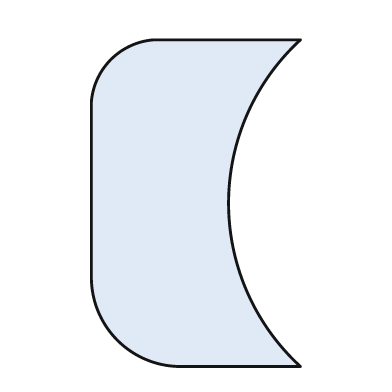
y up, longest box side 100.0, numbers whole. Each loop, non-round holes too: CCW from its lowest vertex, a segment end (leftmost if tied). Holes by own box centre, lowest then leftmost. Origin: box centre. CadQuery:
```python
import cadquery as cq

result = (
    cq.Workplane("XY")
    .moveTo(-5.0, -50.0)
    .lineTo(32.0, -50.0)
    .threePointArc((10.0, 0.0), (32.0, 50.0))
    .lineTo(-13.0, 50.0)
    .threePointArc((-26.0, 44.0), (-32.0, 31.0))
    .lineTo(-32.0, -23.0)
    .threePointArc((-24.0, -42.0), (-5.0, -50.0))
    .close()
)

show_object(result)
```